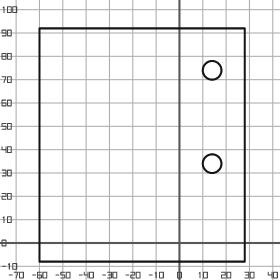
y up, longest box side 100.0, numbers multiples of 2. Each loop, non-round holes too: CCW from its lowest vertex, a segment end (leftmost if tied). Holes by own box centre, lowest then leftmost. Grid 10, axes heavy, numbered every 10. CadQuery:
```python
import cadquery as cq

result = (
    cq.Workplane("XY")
    .moveTo(-60.0, -8.0)
    .lineTo(28.0, -8.0)
    .lineTo(28.0, 92.0)
    .lineTo(-60.0, 92.0)
    .close()
    .moveTo(14.0, 34.0)
    .circle(4.0)
    .moveTo(14.0, 74.0)
    .circle(4.0)
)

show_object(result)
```